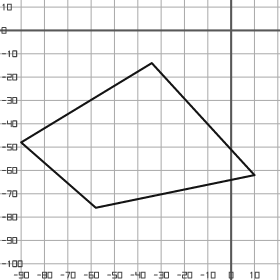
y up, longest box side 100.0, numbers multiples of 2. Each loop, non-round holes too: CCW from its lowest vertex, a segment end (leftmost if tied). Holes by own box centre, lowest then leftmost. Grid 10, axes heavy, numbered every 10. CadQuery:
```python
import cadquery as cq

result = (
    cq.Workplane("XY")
    .moveTo(-58.0, -76.0)
    .lineTo(10.0, -62.0)
    .lineTo(-34.0, -14.0)
    .lineTo(-90.0, -48.0)
    .close()
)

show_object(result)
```